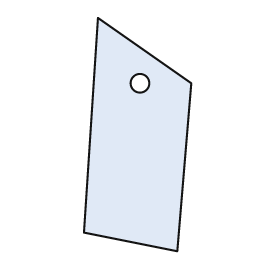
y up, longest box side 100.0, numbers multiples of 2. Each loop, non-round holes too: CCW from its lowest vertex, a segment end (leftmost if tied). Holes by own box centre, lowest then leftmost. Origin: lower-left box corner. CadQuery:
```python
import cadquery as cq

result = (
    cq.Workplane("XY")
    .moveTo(40.0, 0.0)
    .lineTo(46.0, 72.0)
    .lineTo(6.0, 100.0)
    .lineTo(0.0, 8.0)
    .close()
    .moveTo(24.0, 72.0)
    .circle(4.0)
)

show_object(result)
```